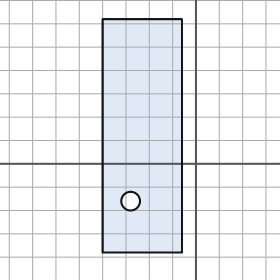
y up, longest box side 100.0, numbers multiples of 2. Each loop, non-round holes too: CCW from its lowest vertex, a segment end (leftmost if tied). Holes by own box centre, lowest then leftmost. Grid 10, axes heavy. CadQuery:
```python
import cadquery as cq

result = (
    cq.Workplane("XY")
    .moveTo(-40.0, -38.0)
    .lineTo(-6.0, -38.0)
    .lineTo(-6.0, 62.0)
    .lineTo(-40.0, 62.0)
    .close()
    .moveTo(-28.0, -16.0)
    .circle(4.0)
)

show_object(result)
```